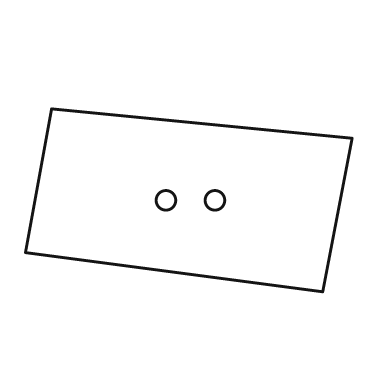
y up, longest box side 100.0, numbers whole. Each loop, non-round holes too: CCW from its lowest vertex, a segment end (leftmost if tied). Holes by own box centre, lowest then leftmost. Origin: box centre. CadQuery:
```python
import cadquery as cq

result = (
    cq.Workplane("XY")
    .moveTo(41.0, -28.0)
    .lineTo(50.0, 19.0)
    .lineTo(-42.0, 28.0)
    .lineTo(-50.0, -16.0)
    .close()
    .moveTo(-7.0, 0.0)
    .circle(3.0)
    .moveTo(8.0, 0.0)
    .circle(3.0)
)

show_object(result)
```